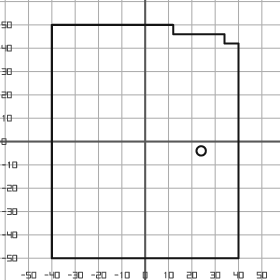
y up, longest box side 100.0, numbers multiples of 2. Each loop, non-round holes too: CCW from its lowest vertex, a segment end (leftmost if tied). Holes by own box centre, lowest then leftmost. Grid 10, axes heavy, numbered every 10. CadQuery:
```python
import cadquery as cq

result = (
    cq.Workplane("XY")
    .moveTo(-40.0, -50.0)
    .lineTo(40.0, -50.0)
    .lineTo(40.0, 42.0)
    .lineTo(34.0, 42.0)
    .lineTo(34.0, 46.0)
    .lineTo(12.0, 46.0)
    .lineTo(12.0, 50.0)
    .lineTo(-40.0, 50.0)
    .close()
    .moveTo(24.0, -4.0)
    .circle(2.0)
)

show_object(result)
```